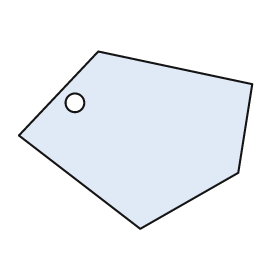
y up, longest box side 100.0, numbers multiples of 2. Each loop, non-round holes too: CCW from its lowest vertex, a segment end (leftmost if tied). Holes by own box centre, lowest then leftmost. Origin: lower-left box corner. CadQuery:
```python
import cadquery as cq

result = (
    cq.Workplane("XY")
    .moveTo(52.0, 0.0)
    .lineTo(94.0, 24.0)
    .lineTo(100.0, 62.0)
    .lineTo(34.0, 76.0)
    .lineTo(0.0, 40.0)
    .close()
    .moveTo(24.0, 54.0)
    .circle(4.0)
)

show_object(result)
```